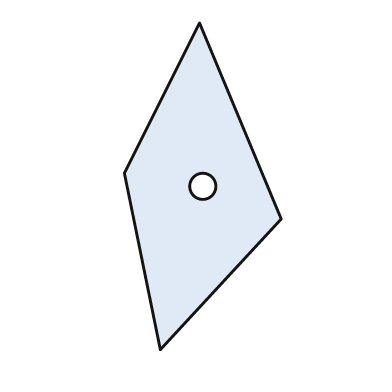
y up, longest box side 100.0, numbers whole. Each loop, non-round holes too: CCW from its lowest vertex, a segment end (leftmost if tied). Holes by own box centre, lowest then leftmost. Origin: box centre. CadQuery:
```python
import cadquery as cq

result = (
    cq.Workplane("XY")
    .moveTo(-13.0, -50.0)
    .lineTo(24.0, -10.0)
    .lineTo(-1.0, 50.0)
    .lineTo(-24.0, 4.0)
    .close()
    .moveTo(0.0, 0.0)
    .circle(4.0)
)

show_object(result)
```